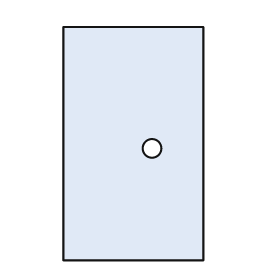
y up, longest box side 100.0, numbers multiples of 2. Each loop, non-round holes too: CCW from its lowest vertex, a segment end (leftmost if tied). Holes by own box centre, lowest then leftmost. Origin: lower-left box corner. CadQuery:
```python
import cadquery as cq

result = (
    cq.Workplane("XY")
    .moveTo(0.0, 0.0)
    .lineTo(60.0, 0.0)
    .lineTo(60.0, 100.0)
    .lineTo(0.0, 100.0)
    .close()
    .moveTo(38.0, 48.0)
    .circle(4.0)
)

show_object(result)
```